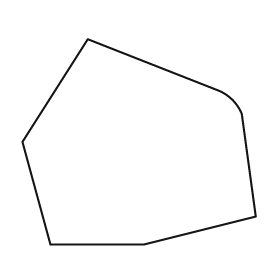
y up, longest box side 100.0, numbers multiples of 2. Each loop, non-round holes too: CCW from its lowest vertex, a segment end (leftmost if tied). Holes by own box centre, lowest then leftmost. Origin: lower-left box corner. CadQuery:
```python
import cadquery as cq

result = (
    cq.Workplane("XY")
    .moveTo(12.0, 0.0)
    .lineTo(52.0, 0.0)
    .lineTo(100.0, 12.0)
    .lineTo(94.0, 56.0)
    .threePointArc((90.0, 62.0), (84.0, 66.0))
    .lineTo(28.0, 88.0)
    .lineTo(0.0, 44.0)
    .close()
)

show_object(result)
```